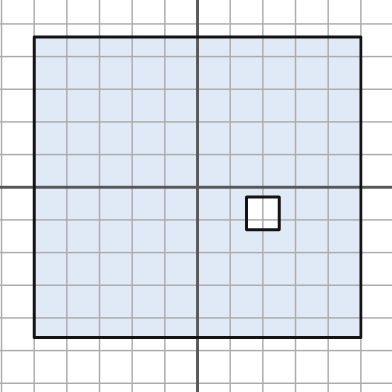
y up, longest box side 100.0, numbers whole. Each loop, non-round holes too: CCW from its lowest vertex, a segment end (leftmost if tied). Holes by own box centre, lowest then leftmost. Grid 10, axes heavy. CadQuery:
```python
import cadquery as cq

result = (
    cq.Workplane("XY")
    .moveTo(-50.0, -46.0)
    .lineTo(50.0, -46.0)
    .lineTo(50.0, 46.0)
    .lineTo(-50.0, 46.0)
    .close()
    .moveTo(15.0, -13.0)
    .lineTo(25.0, -13.0)
    .lineTo(25.0, -3.0)
    .lineTo(15.0, -3.0)
    .close()
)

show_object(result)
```